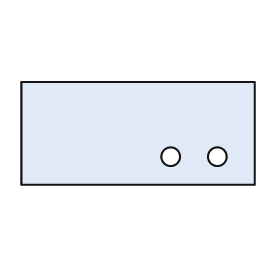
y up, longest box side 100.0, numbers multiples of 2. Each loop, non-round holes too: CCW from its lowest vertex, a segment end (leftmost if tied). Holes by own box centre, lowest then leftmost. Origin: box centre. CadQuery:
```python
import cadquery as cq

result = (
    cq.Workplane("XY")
    .moveTo(-50.0, -22.0)
    .lineTo(50.0, -22.0)
    .lineTo(50.0, 22.0)
    .lineTo(-50.0, 22.0)
    .close()
    .moveTo(14.0, -10.0)
    .circle(4.0)
    .moveTo(34.0, -10.0)
    .circle(4.0)
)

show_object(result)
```